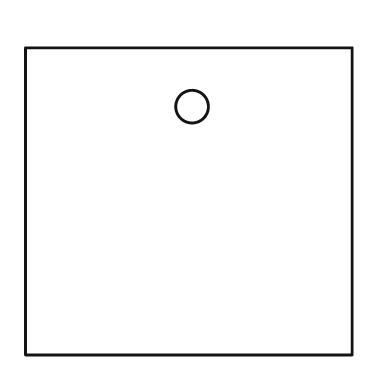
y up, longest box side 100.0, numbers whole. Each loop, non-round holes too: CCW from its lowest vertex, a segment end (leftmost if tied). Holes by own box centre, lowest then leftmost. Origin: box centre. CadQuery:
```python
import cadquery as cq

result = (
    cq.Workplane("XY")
    .moveTo(-50.0, -47.0)
    .lineTo(50.0, -47.0)
    .lineTo(50.0, 47.0)
    .lineTo(-50.0, 47.0)
    .close()
    .moveTo(1.0, 29.0)
    .circle(5.0)
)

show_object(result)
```